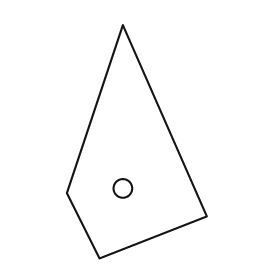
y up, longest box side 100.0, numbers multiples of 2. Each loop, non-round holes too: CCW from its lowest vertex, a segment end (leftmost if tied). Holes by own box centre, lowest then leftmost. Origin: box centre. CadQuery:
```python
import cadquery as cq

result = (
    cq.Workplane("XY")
    .moveTo(-16.0, -50.0)
    .lineTo(30.0, -32.0)
    .lineTo(-6.0, 50.0)
    .lineTo(-30.0, -22.0)
    .close()
    .moveTo(-6.0, -20.0)
    .circle(4.0)
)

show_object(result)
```